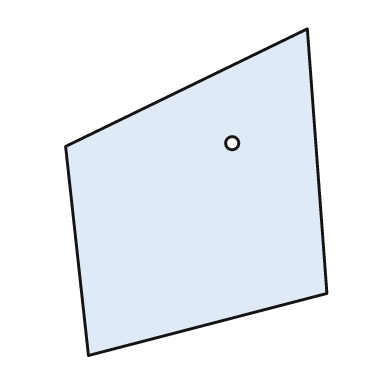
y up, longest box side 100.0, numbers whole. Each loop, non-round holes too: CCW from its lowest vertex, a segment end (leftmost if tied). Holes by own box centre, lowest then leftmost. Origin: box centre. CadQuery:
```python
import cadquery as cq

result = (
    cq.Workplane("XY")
    .moveTo(-33.0, -50.0)
    .lineTo(40.0, -31.0)
    .lineTo(34.0, 50.0)
    .lineTo(-40.0, 14.0)
    .close()
    .moveTo(11.0, 15.0)
    .circle(2.0)
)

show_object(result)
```